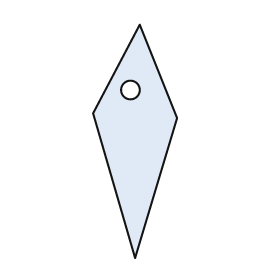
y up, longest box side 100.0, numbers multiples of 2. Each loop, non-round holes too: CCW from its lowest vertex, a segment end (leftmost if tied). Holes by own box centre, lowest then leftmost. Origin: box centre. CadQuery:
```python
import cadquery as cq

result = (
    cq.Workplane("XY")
    .moveTo(0.0, -50.0)
    .lineTo(18.0, 10.0)
    .lineTo(2.0, 50.0)
    .lineTo(-18.0, 12.0)
    .close()
    .moveTo(-2.0, 22.0)
    .circle(4.0)
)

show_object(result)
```